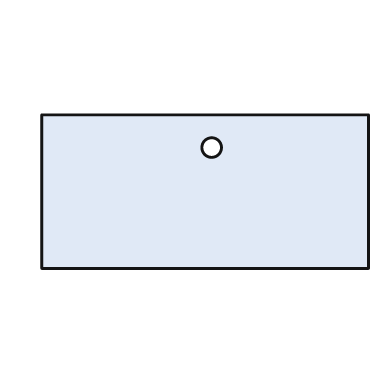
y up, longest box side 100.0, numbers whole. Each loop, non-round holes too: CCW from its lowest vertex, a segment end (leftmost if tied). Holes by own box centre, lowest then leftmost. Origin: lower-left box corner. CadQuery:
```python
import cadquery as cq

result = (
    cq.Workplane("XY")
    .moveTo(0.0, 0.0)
    .lineTo(100.0, 0.0)
    .lineTo(100.0, 47.0)
    .lineTo(0.0, 47.0)
    .close()
    .moveTo(52.0, 37.0)
    .circle(3.0)
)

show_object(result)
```